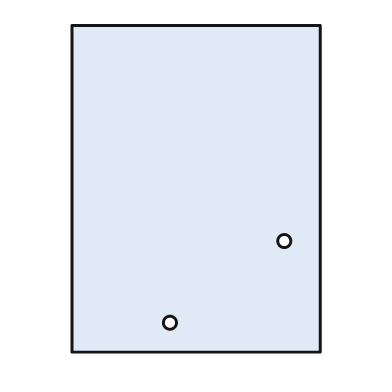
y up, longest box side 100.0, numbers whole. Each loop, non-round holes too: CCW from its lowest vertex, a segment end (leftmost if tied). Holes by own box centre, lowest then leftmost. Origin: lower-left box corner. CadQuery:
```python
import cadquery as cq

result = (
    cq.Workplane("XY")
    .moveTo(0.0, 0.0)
    .lineTo(76.0, 0.0)
    .lineTo(76.0, 100.0)
    .lineTo(0.0, 100.0)
    .close()
    .moveTo(30.0, 9.0)
    .circle(2.0)
    .moveTo(65.0, 34.0)
    .circle(2.0)
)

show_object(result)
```